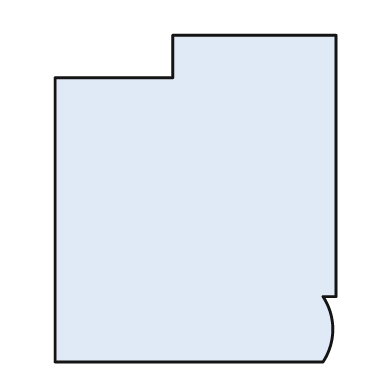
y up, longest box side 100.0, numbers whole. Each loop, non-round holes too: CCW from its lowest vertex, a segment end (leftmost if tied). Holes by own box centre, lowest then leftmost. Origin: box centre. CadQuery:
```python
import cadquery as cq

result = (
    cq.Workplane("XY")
    .moveTo(-43.0, -50.0)
    .lineTo(39.0, -50.0)
    .threePointArc((42.0, -40.0), (39.0, -30.0))
    .lineTo(43.0, -30.0)
    .lineTo(43.0, 50.0)
    .lineTo(-7.0, 50.0)
    .lineTo(-7.0, 37.0)
    .lineTo(-43.0, 37.0)
    .close()
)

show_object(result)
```